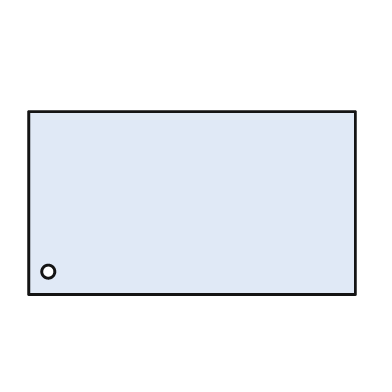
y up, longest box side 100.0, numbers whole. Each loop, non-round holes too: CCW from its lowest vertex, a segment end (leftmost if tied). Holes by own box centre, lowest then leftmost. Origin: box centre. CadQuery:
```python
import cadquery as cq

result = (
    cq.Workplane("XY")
    .moveTo(-50.0, -28.0)
    .lineTo(50.0, -28.0)
    .lineTo(50.0, 28.0)
    .lineTo(-50.0, 28.0)
    .close()
    .moveTo(-44.0, -21.0)
    .circle(2.0)
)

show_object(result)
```